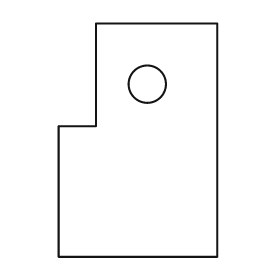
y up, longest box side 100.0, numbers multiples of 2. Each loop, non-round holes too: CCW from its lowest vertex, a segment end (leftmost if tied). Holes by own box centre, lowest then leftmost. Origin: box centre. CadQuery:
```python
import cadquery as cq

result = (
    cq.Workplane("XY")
    .moveTo(-34.0, -50.0)
    .lineTo(34.0, -50.0)
    .lineTo(34.0, 50.0)
    .lineTo(-18.0, 50.0)
    .lineTo(-18.0, 6.0)
    .lineTo(-34.0, 6.0)
    .close()
    .moveTo(4.0, 24.0)
    .circle(8.0)
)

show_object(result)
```